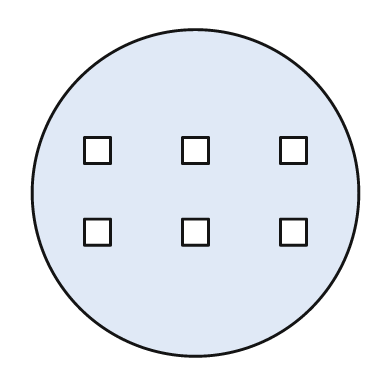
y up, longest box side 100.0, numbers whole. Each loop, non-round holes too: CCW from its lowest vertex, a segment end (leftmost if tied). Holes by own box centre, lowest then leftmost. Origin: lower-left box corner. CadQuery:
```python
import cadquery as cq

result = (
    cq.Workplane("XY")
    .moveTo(50.0, 50.0)
    .circle(50.0)
    .moveTo(16.0, 34.0)
    .lineTo(24.0, 34.0)
    .lineTo(24.0, 42.0)
    .lineTo(16.0, 42.0)
    .close()
    .moveTo(46.0, 34.0)
    .lineTo(54.0, 34.0)
    .lineTo(54.0, 42.0)
    .lineTo(46.0, 42.0)
    .close()
    .moveTo(76.0, 34.0)
    .lineTo(84.0, 34.0)
    .lineTo(84.0, 42.0)
    .lineTo(76.0, 42.0)
    .close()
    .moveTo(16.0, 59.0)
    .lineTo(24.0, 59.0)
    .lineTo(24.0, 67.0)
    .lineTo(16.0, 67.0)
    .close()
    .moveTo(46.0, 59.0)
    .lineTo(54.0, 59.0)
    .lineTo(54.0, 67.0)
    .lineTo(46.0, 67.0)
    .close()
    .moveTo(76.0, 59.0)
    .lineTo(84.0, 59.0)
    .lineTo(84.0, 67.0)
    .lineTo(76.0, 67.0)
    .close()
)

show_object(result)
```